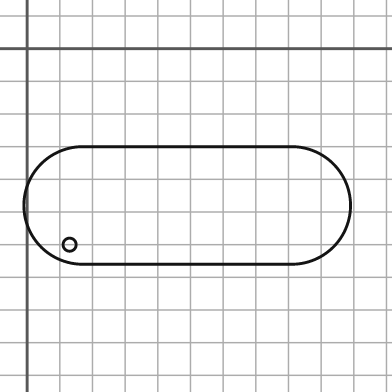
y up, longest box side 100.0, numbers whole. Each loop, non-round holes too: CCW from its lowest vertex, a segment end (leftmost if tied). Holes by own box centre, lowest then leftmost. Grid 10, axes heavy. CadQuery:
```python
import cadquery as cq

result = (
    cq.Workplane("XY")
    .moveTo(17.0, -66.0)
    .lineTo(81.0, -66.0)
    .threePointArc((99.0, -48.0), (81.0, -30.0))
    .lineTo(17.0, -30.0)
    .threePointArc((-1.0, -48.0), (17.0, -66.0))
    .close()
    .moveTo(13.0, -60.0)
    .circle(2.0)
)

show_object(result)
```